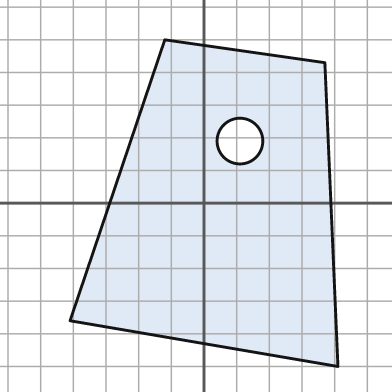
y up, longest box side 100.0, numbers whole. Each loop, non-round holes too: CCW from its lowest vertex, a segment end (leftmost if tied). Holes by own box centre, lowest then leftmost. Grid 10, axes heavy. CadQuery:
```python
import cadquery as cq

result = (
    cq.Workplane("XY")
    .moveTo(41.0, -50.0)
    .lineTo(37.0, 43.0)
    .lineTo(-12.0, 50.0)
    .lineTo(-41.0, -36.0)
    .close()
    .moveTo(11.0, 19.0)
    .circle(7.0)
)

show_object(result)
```